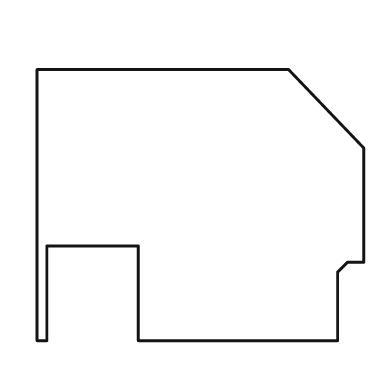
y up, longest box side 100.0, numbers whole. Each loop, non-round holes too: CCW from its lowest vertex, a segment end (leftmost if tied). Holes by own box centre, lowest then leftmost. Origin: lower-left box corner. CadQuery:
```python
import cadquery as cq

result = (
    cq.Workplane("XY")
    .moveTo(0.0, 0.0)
    .lineTo(3.0, 0.0)
    .lineTo(3.0, 29.0)
    .lineTo(31.0, 29.0)
    .lineTo(31.0, 0.0)
    .lineTo(92.0, 0.0)
    .lineTo(92.0, 21.0)
    .lineTo(95.0, 24.0)
    .lineTo(100.0, 24.0)
    .lineTo(100.0, 59.0)
    .lineTo(77.0, 83.0)
    .lineTo(0.0, 83.0)
    .close()
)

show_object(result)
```